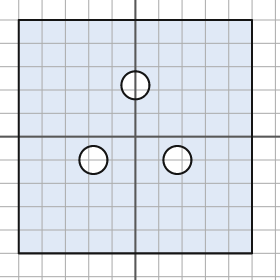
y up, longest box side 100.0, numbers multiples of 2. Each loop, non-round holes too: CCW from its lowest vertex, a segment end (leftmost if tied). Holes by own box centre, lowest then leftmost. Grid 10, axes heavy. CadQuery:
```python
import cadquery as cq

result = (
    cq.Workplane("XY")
    .moveTo(-50.0, -50.0)
    .lineTo(50.0, -50.0)
    .lineTo(50.0, 50.0)
    .lineTo(-50.0, 50.0)
    .close()
    .moveTo(-18.0, -10.0)
    .circle(6.0)
    .moveTo(18.0, -10.0)
    .circle(6.0)
    .moveTo(0.0, 22.0)
    .circle(6.0)
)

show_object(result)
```